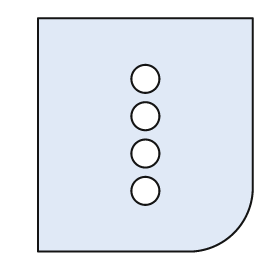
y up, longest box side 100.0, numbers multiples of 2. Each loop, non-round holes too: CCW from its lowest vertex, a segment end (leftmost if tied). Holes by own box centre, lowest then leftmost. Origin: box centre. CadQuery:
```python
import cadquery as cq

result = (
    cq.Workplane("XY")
    .moveTo(-46.0, -50.0)
    .lineTo(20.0, -50.0)
    .threePointArc((38.0, -42.0), (46.0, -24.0))
    .lineTo(46.0, 50.0)
    .lineTo(-46.0, 50.0)
    .close()
    .moveTo(0.0, -24.0)
    .circle(6.0)
    .moveTo(0.0, -8.0)
    .circle(6.0)
    .moveTo(0.0, 8.0)
    .circle(6.0)
    .moveTo(0.0, 24.0)
    .circle(6.0)
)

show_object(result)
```